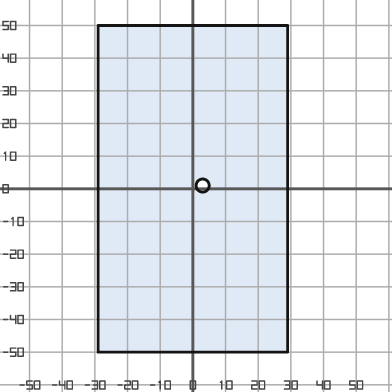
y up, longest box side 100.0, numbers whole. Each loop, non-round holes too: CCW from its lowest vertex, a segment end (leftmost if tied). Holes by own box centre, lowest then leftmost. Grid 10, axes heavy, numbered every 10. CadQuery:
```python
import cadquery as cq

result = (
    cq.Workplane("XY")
    .moveTo(-29.0, -50.0)
    .lineTo(29.0, -50.0)
    .lineTo(29.0, 50.0)
    .lineTo(-29.0, 50.0)
    .close()
    .moveTo(3.0, 1.0)
    .circle(2.0)
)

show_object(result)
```